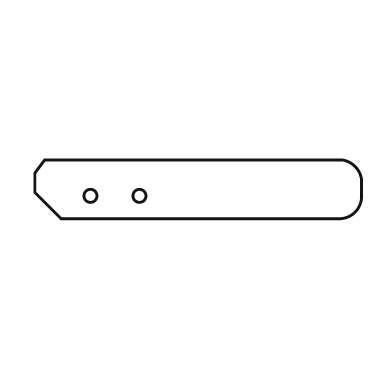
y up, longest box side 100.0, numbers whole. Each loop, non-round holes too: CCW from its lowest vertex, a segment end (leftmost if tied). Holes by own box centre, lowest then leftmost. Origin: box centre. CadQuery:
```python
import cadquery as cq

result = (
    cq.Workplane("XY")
    .moveTo(-42.0, -9.0)
    .lineTo(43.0, -9.0)
    .threePointArc((48.0, -7.0), (50.0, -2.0))
    .lineTo(50.0, 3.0)
    .threePointArc((48.0, 7.0), (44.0, 9.0))
    .lineTo(-47.0, 9.0)
    .lineTo(-50.0, 5.0)
    .lineTo(-50.0, -1.0)
    .close()
    .moveTo(-33.0, -2.0)
    .circle(2.0)
    .moveTo(-18.0, -2.0)
    .circle(2.0)
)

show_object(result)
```